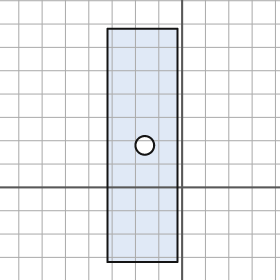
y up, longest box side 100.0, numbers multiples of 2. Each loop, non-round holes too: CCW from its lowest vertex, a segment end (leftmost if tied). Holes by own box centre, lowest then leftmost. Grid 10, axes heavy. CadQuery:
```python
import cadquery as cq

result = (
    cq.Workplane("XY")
    .moveTo(-32.0, -32.0)
    .lineTo(-2.0, -32.0)
    .lineTo(-2.0, 68.0)
    .lineTo(-32.0, 68.0)
    .close()
    .moveTo(-16.0, 18.0)
    .circle(4.0)
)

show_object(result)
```